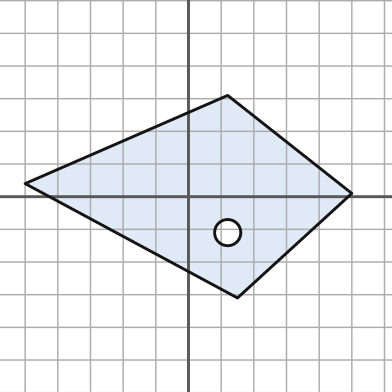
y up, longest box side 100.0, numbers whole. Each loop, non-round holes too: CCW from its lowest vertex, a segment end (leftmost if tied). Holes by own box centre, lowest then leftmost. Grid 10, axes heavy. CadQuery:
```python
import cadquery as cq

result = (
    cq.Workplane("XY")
    .moveTo(15.0, -31.0)
    .lineTo(50.0, 1.0)
    .lineTo(12.0, 31.0)
    .lineTo(-50.0, 4.0)
    .close()
    .moveTo(12.0, -11.0)
    .circle(4.0)
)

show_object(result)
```